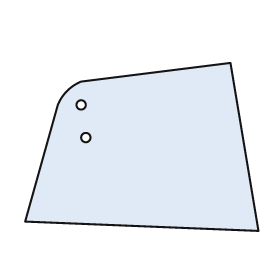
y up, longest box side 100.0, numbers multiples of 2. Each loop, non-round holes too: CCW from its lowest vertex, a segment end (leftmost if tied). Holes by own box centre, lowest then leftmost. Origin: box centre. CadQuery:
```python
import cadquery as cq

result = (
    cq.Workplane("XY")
    .moveTo(50.0, -36.0)
    .lineTo(38.0, 36.0)
    .lineTo(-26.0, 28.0)
    .threePointArc((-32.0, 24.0), (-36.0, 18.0))
    .lineTo(-50.0, -32.0)
    .close()
    .moveTo(-24.0, 4.0)
    .circle(2.0)
    .moveTo(-26.0, 18.0)
    .circle(2.0)
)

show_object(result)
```